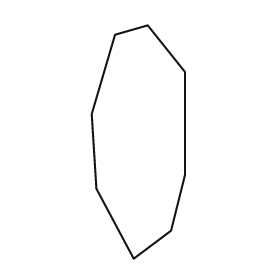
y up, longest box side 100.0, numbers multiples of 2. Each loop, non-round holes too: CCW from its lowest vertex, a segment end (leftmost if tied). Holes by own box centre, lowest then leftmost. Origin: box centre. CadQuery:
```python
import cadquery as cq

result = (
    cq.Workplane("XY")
    .moveTo(-2.0, -50.0)
    .lineTo(14.0, -38.0)
    .lineTo(20.0, -14.0)
    .lineTo(20.0, 30.0)
    .lineTo(4.0, 50.0)
    .lineTo(-10.0, 46.0)
    .lineTo(-20.0, 12.0)
    .lineTo(-18.0, -20.0)
    .close()
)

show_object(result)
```